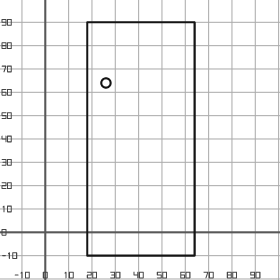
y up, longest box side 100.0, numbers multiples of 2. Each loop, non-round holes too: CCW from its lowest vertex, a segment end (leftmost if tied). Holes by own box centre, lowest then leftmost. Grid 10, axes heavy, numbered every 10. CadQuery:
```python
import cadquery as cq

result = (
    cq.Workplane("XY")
    .moveTo(18.0, -10.0)
    .lineTo(64.0, -10.0)
    .lineTo(64.0, 90.0)
    .lineTo(18.0, 90.0)
    .close()
    .moveTo(26.0, 64.0)
    .circle(2.0)
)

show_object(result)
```